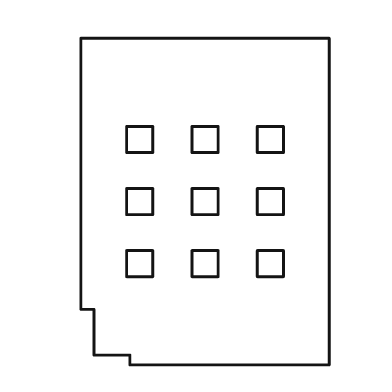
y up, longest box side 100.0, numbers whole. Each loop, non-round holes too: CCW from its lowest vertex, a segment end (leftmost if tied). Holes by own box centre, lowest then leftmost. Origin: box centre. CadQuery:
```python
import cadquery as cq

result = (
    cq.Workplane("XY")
    .moveTo(-23.0, -50.0)
    .lineTo(38.0, -50.0)
    .lineTo(38.0, 50.0)
    .lineTo(-38.0, 50.0)
    .lineTo(-38.0, -33.0)
    .lineTo(-34.0, -33.0)
    .lineTo(-34.0, -47.0)
    .lineTo(-23.0, -47.0)
    .close()
    .moveTo(-24.0, -23.0)
    .lineTo(-16.0, -23.0)
    .lineTo(-16.0, -15.0)
    .lineTo(-24.0, -15.0)
    .close()
    .moveTo(-4.0, -23.0)
    .lineTo(4.0, -23.0)
    .lineTo(4.0, -15.0)
    .lineTo(-4.0, -15.0)
    .close()
    .moveTo(16.0, -23.0)
    .lineTo(24.0, -23.0)
    .lineTo(24.0, -15.0)
    .lineTo(16.0, -15.0)
    .close()
    .moveTo(-24.0, -4.0)
    .lineTo(-16.0, -4.0)
    .lineTo(-16.0, 4.0)
    .lineTo(-24.0, 4.0)
    .close()
    .moveTo(-4.0, -4.0)
    .lineTo(4.0, -4.0)
    .lineTo(4.0, 4.0)
    .lineTo(-4.0, 4.0)
    .close()
    .moveTo(16.0, -4.0)
    .lineTo(24.0, -4.0)
    .lineTo(24.0, 4.0)
    .lineTo(16.0, 4.0)
    .close()
    .moveTo(-24.0, 15.0)
    .lineTo(-16.0, 15.0)
    .lineTo(-16.0, 23.0)
    .lineTo(-24.0, 23.0)
    .close()
    .moveTo(-4.0, 15.0)
    .lineTo(4.0, 15.0)
    .lineTo(4.0, 23.0)
    .lineTo(-4.0, 23.0)
    .close()
    .moveTo(16.0, 15.0)
    .lineTo(24.0, 15.0)
    .lineTo(24.0, 23.0)
    .lineTo(16.0, 23.0)
    .close()
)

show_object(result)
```